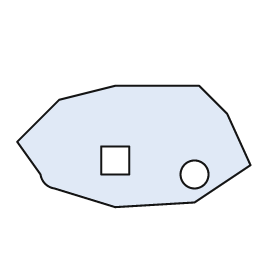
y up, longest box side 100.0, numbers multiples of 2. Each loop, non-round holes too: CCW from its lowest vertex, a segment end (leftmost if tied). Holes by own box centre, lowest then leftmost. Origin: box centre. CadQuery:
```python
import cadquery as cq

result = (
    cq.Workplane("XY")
    .moveTo(-8.0, -26.0)
    .lineTo(26.0, -24.0)
    .lineTo(50.0, -8.0)
    .lineTo(40.0, 14.0)
    .lineTo(28.0, 26.0)
    .lineTo(-8.0, 26.0)
    .lineTo(-32.0, 20.0)
    .lineTo(-50.0, 2.0)
    .lineTo(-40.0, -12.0)
    .threePointArc((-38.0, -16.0), (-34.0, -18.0))
    .close()
    .moveTo(26.0, -12.0)
    .circle(6.0)
    .moveTo(-14.0, -12.0)
    .lineTo(-2.0, -12.0)
    .lineTo(-2.0, 0.0)
    .lineTo(-14.0, 0.0)
    .close()
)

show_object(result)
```